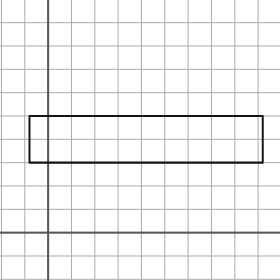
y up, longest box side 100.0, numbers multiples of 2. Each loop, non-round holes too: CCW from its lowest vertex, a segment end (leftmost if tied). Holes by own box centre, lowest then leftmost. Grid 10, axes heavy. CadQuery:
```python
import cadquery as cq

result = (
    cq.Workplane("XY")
    .moveTo(-8.0, 30.0)
    .lineTo(92.0, 30.0)
    .lineTo(92.0, 50.0)
    .lineTo(-8.0, 50.0)
    .close()
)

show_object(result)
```